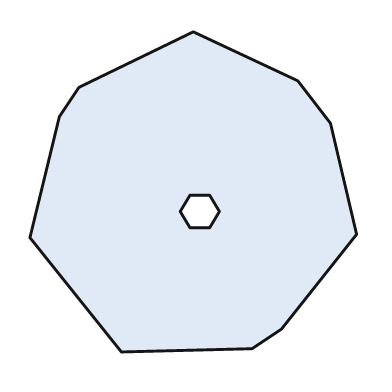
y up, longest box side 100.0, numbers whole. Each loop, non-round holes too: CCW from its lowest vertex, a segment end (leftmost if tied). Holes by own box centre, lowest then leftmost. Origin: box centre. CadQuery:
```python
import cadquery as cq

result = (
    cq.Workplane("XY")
    .moveTo(-22.0, -49.0)
    .lineTo(18.0, -48.0)
    .lineTo(27.0, -42.0)
    .lineTo(50.0, -13.0)
    .lineTo(42.0, 21.0)
    .lineTo(32.0, 34.0)
    .lineTo(0.0, 49.0)
    .lineTo(-35.0, 32.0)
    .lineTo(-41.0, 23.0)
    .lineTo(-50.0, -14.0)
    .close()
    .moveTo(-1.0, -11.0)
    .lineTo(5.0, -11.0)
    .lineTo(8.0, -6.0)
    .lineTo(5.0, -1.0)
    .lineTo(-1.0, -1.0)
    .lineTo(-4.0, -6.0)
    .close()
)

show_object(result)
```